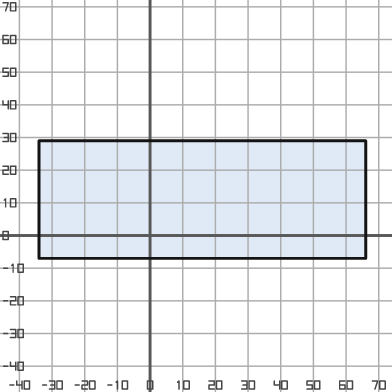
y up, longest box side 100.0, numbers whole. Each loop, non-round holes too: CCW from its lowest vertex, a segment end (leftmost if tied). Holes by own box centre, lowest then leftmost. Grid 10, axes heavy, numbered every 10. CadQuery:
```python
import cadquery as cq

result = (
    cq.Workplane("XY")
    .moveTo(-34.0, -7.0)
    .lineTo(66.0, -7.0)
    .lineTo(66.0, 29.0)
    .lineTo(-34.0, 29.0)
    .close()
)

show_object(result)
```